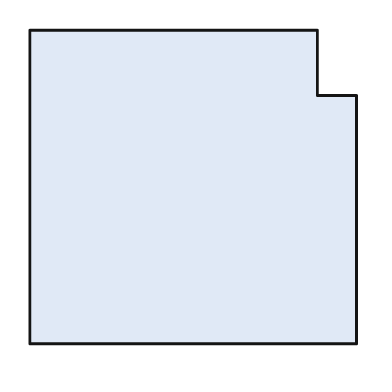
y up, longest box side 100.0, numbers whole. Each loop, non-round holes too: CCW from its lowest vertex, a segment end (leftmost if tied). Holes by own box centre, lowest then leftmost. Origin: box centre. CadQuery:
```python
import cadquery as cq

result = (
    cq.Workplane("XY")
    .moveTo(-50.0, -48.0)
    .lineTo(50.0, -48.0)
    .lineTo(50.0, 28.0)
    .lineTo(38.0, 28.0)
    .lineTo(38.0, 48.0)
    .lineTo(-50.0, 48.0)
    .close()
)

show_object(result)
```